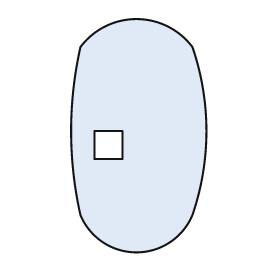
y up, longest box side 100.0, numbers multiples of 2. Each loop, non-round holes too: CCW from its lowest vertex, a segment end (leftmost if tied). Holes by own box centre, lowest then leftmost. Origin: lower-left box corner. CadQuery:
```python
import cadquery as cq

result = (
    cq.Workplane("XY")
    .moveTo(4.0, 16.0)
    .threePointArc((28.0, 0.0), (52.0, 16.0))
    .threePointArc((58.0, 52.0), (52.0, 88.0))
    .threePointArc((28.0, 100.0), (4.0, 88.0))
    .threePointArc((0.0, 52.0), (4.0, 16.0))
    .close()
    .moveTo(10.0, 40.0)
    .lineTo(22.0, 40.0)
    .lineTo(22.0, 52.0)
    .lineTo(10.0, 52.0)
    .close()
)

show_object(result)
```